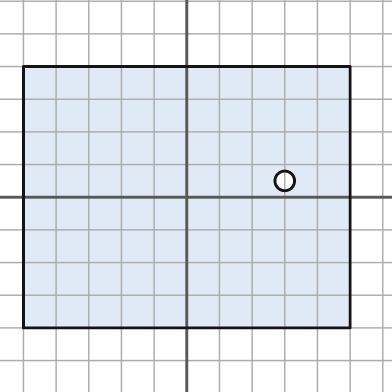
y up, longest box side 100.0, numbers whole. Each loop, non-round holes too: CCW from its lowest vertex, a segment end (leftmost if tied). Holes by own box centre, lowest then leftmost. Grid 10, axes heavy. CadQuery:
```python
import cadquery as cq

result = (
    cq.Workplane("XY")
    .moveTo(-50.0, -40.0)
    .lineTo(50.0, -40.0)
    .lineTo(50.0, 40.0)
    .lineTo(-50.0, 40.0)
    .close()
    .moveTo(30.0, 5.0)
    .circle(3.0)
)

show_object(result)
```